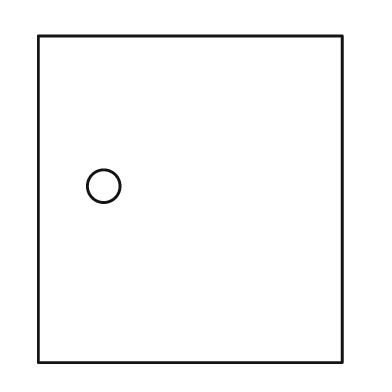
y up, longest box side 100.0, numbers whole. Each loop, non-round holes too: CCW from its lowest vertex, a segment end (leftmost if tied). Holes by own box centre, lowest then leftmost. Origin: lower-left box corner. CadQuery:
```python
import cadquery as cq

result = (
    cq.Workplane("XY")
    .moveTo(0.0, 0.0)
    .lineTo(93.0, 0.0)
    .lineTo(93.0, 100.0)
    .lineTo(0.0, 100.0)
    .close()
    .moveTo(20.0, 54.0)
    .circle(5.0)
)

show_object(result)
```